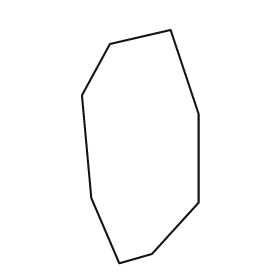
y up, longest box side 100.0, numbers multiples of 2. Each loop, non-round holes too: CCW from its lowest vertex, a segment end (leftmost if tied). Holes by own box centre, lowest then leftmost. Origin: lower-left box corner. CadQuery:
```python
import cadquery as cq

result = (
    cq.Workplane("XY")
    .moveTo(16.0, 0.0)
    .lineTo(30.0, 4.0)
    .lineTo(50.0, 26.0)
    .lineTo(50.0, 64.0)
    .lineTo(38.0, 100.0)
    .lineTo(12.0, 94.0)
    .lineTo(0.0, 72.0)
    .lineTo(4.0, 28.0)
    .close()
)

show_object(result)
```